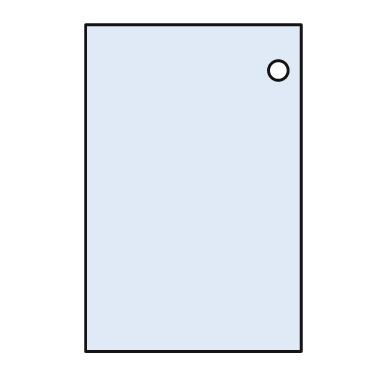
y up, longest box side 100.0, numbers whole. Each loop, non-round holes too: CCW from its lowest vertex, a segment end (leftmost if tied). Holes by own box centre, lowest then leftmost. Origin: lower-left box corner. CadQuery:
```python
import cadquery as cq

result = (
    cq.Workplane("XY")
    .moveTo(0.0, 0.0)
    .lineTo(66.0, 0.0)
    .lineTo(66.0, 100.0)
    .lineTo(0.0, 100.0)
    .close()
    .moveTo(59.0, 86.0)
    .circle(3.0)
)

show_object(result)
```